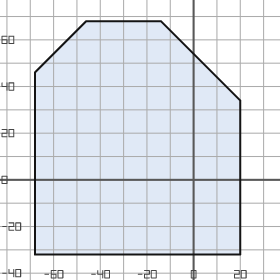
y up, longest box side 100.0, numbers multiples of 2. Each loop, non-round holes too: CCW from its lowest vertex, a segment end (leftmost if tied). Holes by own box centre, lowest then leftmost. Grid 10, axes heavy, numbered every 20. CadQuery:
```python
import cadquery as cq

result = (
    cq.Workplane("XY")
    .moveTo(-68.0, -32.0)
    .lineTo(20.0, -32.0)
    .lineTo(20.0, 34.0)
    .lineTo(-14.0, 68.0)
    .lineTo(-46.0, 68.0)
    .lineTo(-68.0, 46.0)
    .close()
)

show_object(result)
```